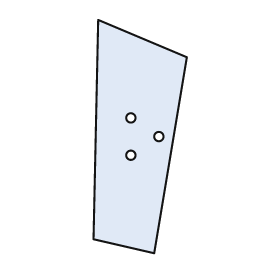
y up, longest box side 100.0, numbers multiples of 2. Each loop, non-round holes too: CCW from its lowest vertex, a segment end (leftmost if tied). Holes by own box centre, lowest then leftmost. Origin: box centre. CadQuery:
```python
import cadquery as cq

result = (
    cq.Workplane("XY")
    .moveTo(6.0, -50.0)
    .lineTo(20.0, 34.0)
    .lineTo(-18.0, 50.0)
    .lineTo(-20.0, -44.0)
    .close()
    .moveTo(-4.0, -8.0)
    .circle(2.0)
    .moveTo(8.0, 0.0)
    .circle(2.0)
    .moveTo(-4.0, 8.0)
    .circle(2.0)
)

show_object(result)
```